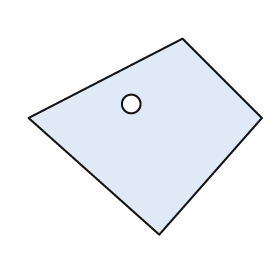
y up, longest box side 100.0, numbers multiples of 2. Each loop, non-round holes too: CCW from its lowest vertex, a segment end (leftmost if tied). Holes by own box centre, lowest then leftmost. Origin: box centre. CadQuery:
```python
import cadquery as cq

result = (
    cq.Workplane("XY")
    .moveTo(6.0, -42.0)
    .lineTo(50.0, 8.0)
    .lineTo(16.0, 42.0)
    .lineTo(-50.0, 8.0)
    .close()
    .moveTo(-6.0, 14.0)
    .circle(4.0)
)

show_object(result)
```